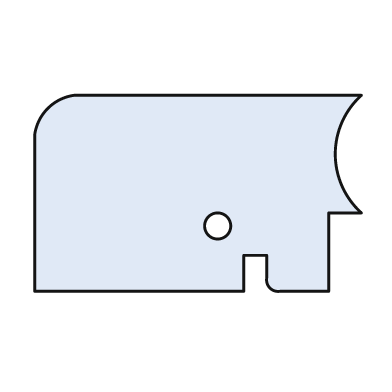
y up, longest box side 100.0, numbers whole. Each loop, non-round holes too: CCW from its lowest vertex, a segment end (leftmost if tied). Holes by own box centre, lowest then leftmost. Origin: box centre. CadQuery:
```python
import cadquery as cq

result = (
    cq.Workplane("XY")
    .moveTo(-50.0, -30.0)
    .lineTo(14.0, -30.0)
    .lineTo(14.0, -19.0)
    .lineTo(21.0, -19.0)
    .lineTo(21.0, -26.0)
    .threePointArc((22.0, -29.0), (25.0, -30.0))
    .lineTo(40.0, -30.0)
    .lineTo(40.0, -6.0)
    .lineTo(50.0, -6.0)
    .threePointArc((42.0, 12.0), (50.0, 30.0))
    .lineTo(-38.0, 30.0)
    .threePointArc((-46.0, 26.0), (-50.0, 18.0))
    .close()
    .moveTo(6.0, -10.0)
    .circle(4.0)
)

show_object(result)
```